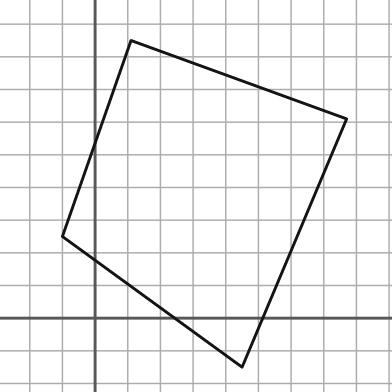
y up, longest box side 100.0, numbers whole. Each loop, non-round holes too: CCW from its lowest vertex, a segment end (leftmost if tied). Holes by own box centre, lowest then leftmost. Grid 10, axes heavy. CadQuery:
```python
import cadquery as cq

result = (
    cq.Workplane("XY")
    .moveTo(45.0, -15.0)
    .lineTo(77.0, 61.0)
    .lineTo(11.0, 85.0)
    .lineTo(-10.0, 25.0)
    .close()
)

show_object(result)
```